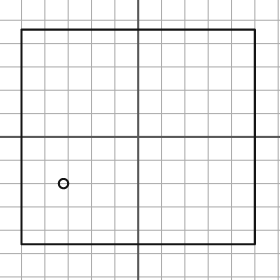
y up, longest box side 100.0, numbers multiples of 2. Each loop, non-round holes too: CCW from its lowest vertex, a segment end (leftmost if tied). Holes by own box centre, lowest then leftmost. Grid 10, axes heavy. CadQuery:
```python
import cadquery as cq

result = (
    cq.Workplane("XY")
    .moveTo(-50.0, -46.0)
    .lineTo(50.0, -46.0)
    .lineTo(50.0, 46.0)
    .lineTo(-50.0, 46.0)
    .close()
    .moveTo(-32.0, -20.0)
    .circle(2.0)
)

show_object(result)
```